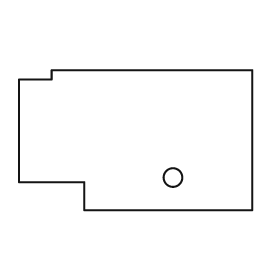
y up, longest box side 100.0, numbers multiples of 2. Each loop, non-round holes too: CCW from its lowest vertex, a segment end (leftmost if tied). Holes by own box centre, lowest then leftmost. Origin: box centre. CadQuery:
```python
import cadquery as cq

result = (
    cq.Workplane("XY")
    .moveTo(-22.0, -30.0)
    .lineTo(50.0, -30.0)
    .lineTo(50.0, 30.0)
    .lineTo(-36.0, 30.0)
    .lineTo(-36.0, 26.0)
    .lineTo(-50.0, 26.0)
    .lineTo(-50.0, -18.0)
    .lineTo(-22.0, -18.0)
    .close()
    .moveTo(16.0, -16.0)
    .circle(4.0)
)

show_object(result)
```